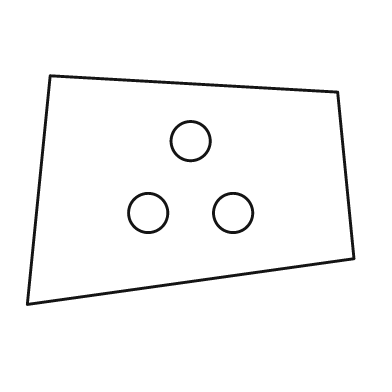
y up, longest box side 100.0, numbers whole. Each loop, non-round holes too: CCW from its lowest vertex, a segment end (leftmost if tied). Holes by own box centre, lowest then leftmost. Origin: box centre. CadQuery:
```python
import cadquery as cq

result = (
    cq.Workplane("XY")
    .moveTo(-50.0, -35.0)
    .lineTo(50.0, -21.0)
    .lineTo(45.0, 30.0)
    .lineTo(-43.0, 35.0)
    .close()
    .moveTo(-13.0, -7.0)
    .circle(6.0)
    .moveTo(13.0, -7.0)
    .circle(6.0)
    .moveTo(0.0, 15.0)
    .circle(6.0)
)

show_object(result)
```